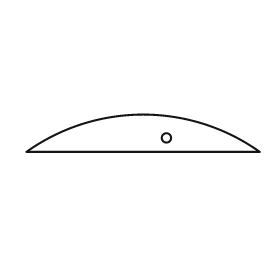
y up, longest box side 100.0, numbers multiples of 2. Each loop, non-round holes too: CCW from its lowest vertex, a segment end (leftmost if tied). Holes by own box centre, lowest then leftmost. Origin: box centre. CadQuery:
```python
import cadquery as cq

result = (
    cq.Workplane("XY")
    .moveTo(-50.0, -8.0)
    .lineTo(50.0, -8.0)
    .threePointArc((0.0, 8.0), (-50.0, -8.0))
    .close()
    .moveTo(10.0, -2.0)
    .circle(2.0)
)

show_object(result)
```